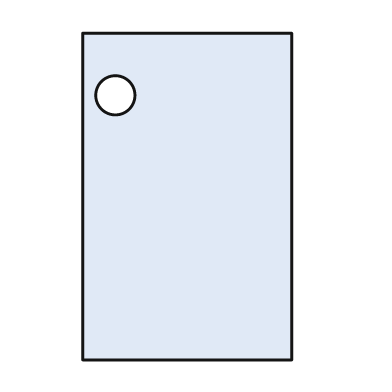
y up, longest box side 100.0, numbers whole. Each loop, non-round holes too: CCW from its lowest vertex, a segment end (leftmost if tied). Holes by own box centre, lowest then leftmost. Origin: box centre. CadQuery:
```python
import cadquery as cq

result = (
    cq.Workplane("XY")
    .moveTo(-32.0, -50.0)
    .lineTo(32.0, -50.0)
    .lineTo(32.0, 50.0)
    .lineTo(-32.0, 50.0)
    .close()
    .moveTo(-22.0, 31.0)
    .circle(6.0)
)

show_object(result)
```